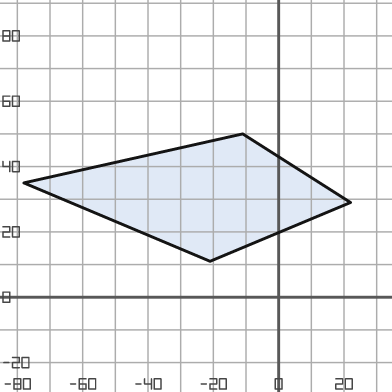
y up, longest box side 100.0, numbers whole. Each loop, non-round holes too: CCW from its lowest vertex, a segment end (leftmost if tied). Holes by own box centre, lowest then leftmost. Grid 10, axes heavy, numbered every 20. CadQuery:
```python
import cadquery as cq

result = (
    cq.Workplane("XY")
    .moveTo(-21.0, 11.0)
    .lineTo(22.0, 29.0)
    .lineTo(-11.0, 50.0)
    .lineTo(-78.0, 35.0)
    .close()
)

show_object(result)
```